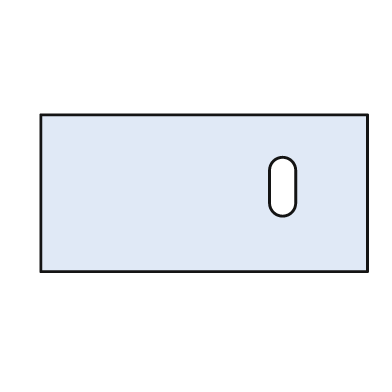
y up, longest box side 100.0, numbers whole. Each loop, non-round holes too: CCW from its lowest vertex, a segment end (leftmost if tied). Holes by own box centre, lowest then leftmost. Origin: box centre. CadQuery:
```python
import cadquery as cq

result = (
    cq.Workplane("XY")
    .moveTo(-50.0, -24.0)
    .lineTo(50.0, -24.0)
    .lineTo(50.0, 24.0)
    .lineTo(-50.0, 24.0)
    .close()
    .moveTo(20.0, -3.0)
    .threePointArc((24.0, -7.0), (28.0, -3.0))
    .lineTo(28.0, 7.0)
    .threePointArc((24.0, 11.0), (20.0, 7.0))
    .close()
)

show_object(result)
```